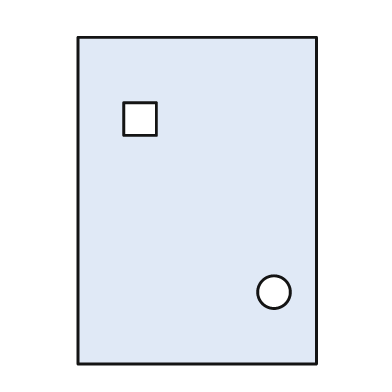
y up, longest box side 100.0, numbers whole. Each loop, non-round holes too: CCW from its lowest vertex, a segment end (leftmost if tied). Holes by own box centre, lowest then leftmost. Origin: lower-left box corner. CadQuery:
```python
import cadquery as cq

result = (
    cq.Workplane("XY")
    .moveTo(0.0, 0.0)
    .lineTo(73.0, 0.0)
    .lineTo(73.0, 100.0)
    .lineTo(0.0, 100.0)
    .close()
    .moveTo(60.0, 22.0)
    .circle(5.0)
    .moveTo(14.0, 70.0)
    .lineTo(24.0, 70.0)
    .lineTo(24.0, 80.0)
    .lineTo(14.0, 80.0)
    .close()
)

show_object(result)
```